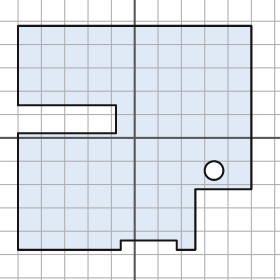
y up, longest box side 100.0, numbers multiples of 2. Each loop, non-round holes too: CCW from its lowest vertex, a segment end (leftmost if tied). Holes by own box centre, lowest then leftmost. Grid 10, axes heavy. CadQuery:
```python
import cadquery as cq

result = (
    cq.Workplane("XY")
    .moveTo(-50.0, -48.0)
    .lineTo(-6.0, -48.0)
    .lineTo(-6.0, -44.0)
    .lineTo(18.0, -44.0)
    .lineTo(18.0, -48.0)
    .lineTo(26.0, -48.0)
    .lineTo(26.0, -22.0)
    .lineTo(50.0, -22.0)
    .lineTo(50.0, 48.0)
    .lineTo(-50.0, 48.0)
    .lineTo(-50.0, 14.0)
    .lineTo(-8.0, 14.0)
    .lineTo(-8.0, 2.0)
    .lineTo(-50.0, 2.0)
    .close()
    .moveTo(34.0, -14.0)
    .circle(4.0)
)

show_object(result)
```